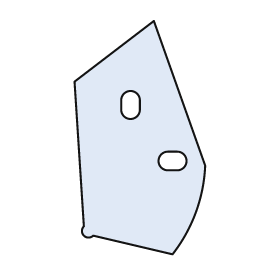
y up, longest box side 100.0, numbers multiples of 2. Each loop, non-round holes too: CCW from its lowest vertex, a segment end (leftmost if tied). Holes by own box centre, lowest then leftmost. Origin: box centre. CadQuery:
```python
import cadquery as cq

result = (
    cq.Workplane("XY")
    .moveTo(14.0, -50.0)
    .threePointArc((24.0, -32.0), (28.0, -12.0))
    .lineTo(6.0, 50.0)
    .lineTo(-28.0, 24.0)
    .lineTo(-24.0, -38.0)
    .threePointArc((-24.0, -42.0), (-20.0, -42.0))
    .close()
    .moveTo(12.0, -14.0)
    .lineTo(16.0, -14.0)
    .threePointArc((20.0, -10.0), (16.0, -6.0))
    .lineTo(12.0, -6.0)
    .threePointArc((8.0, -10.0), (12.0, -14.0))
    .close()
    .moveTo(-8.0, 12.0)
    .threePointArc((-4.0, 8.0), (0.0, 12.0))
    .lineTo(0.0, 16.0)
    .threePointArc((-4.0, 20.0), (-8.0, 16.0))
    .close()
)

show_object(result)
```